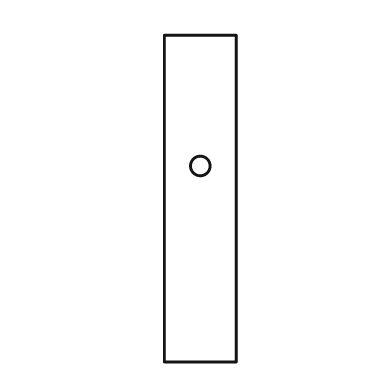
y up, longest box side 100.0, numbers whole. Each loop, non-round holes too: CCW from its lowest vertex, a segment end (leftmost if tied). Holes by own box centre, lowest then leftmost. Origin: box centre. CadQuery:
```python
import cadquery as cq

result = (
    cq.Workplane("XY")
    .moveTo(-11.0, -50.0)
    .lineTo(11.0, -50.0)
    .lineTo(11.0, 50.0)
    .lineTo(-11.0, 50.0)
    .close()
    .moveTo(0.0, 10.0)
    .circle(3.0)
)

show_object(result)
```